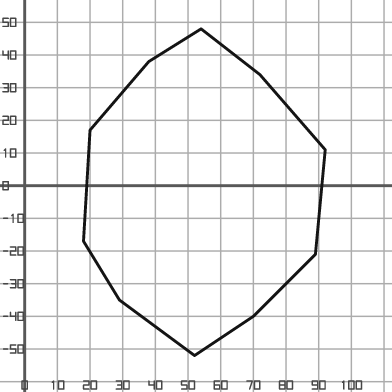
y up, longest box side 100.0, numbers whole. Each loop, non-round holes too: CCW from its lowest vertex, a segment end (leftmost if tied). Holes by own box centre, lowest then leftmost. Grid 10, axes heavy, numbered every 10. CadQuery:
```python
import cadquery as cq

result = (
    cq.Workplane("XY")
    .moveTo(52.0, -52.0)
    .lineTo(70.0, -40.0)
    .lineTo(89.0, -21.0)
    .lineTo(92.0, 11.0)
    .lineTo(72.0, 34.0)
    .lineTo(54.0, 48.0)
    .lineTo(38.0, 38.0)
    .lineTo(20.0, 17.0)
    .lineTo(18.0, -17.0)
    .lineTo(29.0, -35.0)
    .close()
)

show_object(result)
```